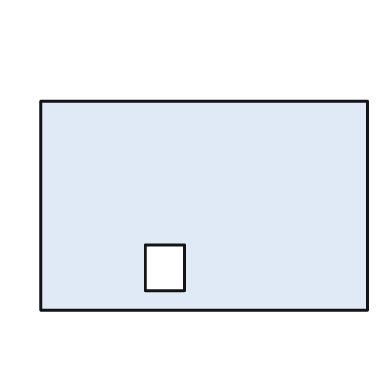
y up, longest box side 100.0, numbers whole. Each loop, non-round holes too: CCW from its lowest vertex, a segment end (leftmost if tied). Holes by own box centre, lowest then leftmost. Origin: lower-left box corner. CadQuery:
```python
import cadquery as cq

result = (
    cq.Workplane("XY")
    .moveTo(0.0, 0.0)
    .lineTo(100.0, 0.0)
    .lineTo(100.0, 64.0)
    .lineTo(0.0, 64.0)
    .close()
    .moveTo(32.0, 6.0)
    .lineTo(44.0, 6.0)
    .lineTo(44.0, 20.0)
    .lineTo(32.0, 20.0)
    .close()
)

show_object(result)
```